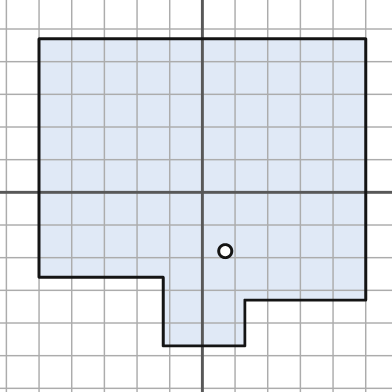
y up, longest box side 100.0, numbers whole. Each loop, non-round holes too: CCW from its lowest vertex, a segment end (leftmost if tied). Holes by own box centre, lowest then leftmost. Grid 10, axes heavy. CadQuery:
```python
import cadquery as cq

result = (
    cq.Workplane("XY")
    .moveTo(-12.0, -47.0)
    .lineTo(13.0, -47.0)
    .lineTo(13.0, -33.0)
    .lineTo(50.0, -33.0)
    .lineTo(50.0, 47.0)
    .lineTo(-50.0, 47.0)
    .lineTo(-50.0, -26.0)
    .lineTo(-12.0, -26.0)
    .close()
    .moveTo(7.0, -18.0)
    .circle(2.0)
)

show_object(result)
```